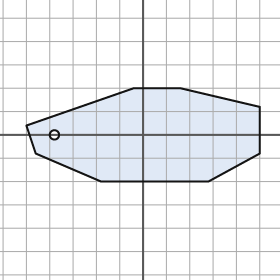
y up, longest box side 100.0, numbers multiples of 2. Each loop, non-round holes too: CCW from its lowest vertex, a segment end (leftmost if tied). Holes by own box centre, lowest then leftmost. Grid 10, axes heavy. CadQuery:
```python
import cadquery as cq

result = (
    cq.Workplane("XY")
    .moveTo(-18.0, -20.0)
    .lineTo(28.0, -20.0)
    .lineTo(50.0, -8.0)
    .lineTo(50.0, 12.0)
    .lineTo(16.0, 20.0)
    .lineTo(-4.0, 20.0)
    .lineTo(-50.0, 4.0)
    .lineTo(-46.0, -8.0)
    .close()
    .moveTo(-38.0, 0.0)
    .circle(2.0)
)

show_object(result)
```